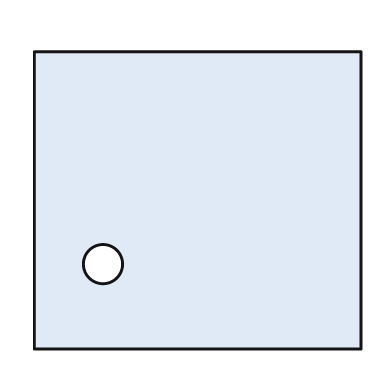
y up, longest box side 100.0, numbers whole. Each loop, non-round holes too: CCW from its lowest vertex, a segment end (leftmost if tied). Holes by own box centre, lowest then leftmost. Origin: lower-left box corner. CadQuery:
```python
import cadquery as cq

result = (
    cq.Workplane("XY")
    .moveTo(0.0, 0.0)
    .lineTo(100.0, 0.0)
    .lineTo(100.0, 91.0)
    .lineTo(0.0, 91.0)
    .close()
    .moveTo(21.0, 26.0)
    .circle(6.0)
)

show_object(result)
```